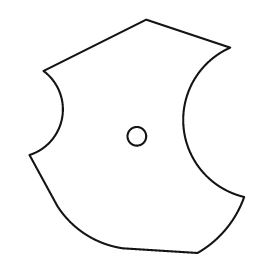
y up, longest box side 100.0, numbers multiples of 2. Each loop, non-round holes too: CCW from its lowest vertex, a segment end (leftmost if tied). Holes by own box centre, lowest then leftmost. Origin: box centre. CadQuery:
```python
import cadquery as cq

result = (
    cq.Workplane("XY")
    .moveTo(26.0, -50.0)
    .threePointArc((38.0, -40.0), (46.0, -26.0))
    .threePointArc((20.0, 4.0), (40.0, 38.0))
    .lineTo(4.0, 50.0)
    .lineTo(-40.0, 28.0)
    .threePointArc((-32.0, 8.0), (-46.0, -8.0))
    .lineTo(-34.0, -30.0)
    .threePointArc((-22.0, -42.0), (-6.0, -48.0))
    .close()
    .moveTo(0.0, 0.0)
    .circle(4.0)
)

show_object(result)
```